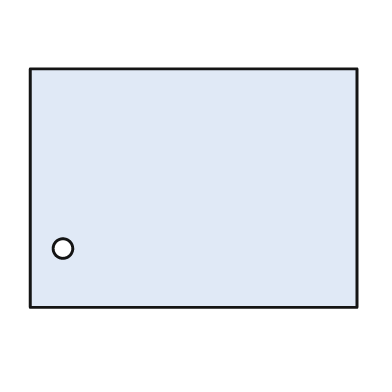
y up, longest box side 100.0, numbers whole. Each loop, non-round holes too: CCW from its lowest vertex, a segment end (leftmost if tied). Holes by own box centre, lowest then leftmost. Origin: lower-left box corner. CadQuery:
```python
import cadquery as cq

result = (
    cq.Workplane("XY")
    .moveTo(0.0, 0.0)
    .lineTo(100.0, 0.0)
    .lineTo(100.0, 73.0)
    .lineTo(0.0, 73.0)
    .close()
    .moveTo(10.0, 18.0)
    .circle(3.0)
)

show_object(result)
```